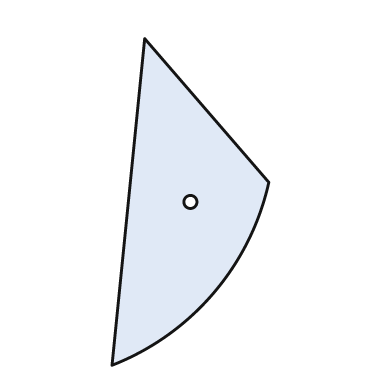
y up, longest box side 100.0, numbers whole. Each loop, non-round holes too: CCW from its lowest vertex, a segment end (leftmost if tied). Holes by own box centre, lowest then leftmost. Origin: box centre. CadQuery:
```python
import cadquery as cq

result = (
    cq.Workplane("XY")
    .moveTo(-24.0, -50.0)
    .threePointArc((7.0, -28.0), (24.0, 6.0))
    .lineTo(-14.0, 50.0)
    .close()
    .moveTo(0.0, 0.0)
    .circle(2.0)
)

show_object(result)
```